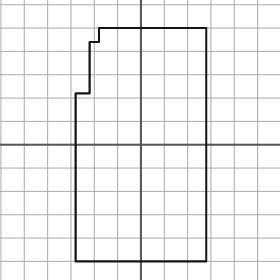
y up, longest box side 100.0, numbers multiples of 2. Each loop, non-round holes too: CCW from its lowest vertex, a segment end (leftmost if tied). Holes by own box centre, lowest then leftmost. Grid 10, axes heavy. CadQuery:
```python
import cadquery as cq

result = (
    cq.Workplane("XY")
    .moveTo(-28.0, -50.0)
    .lineTo(28.0, -50.0)
    .lineTo(28.0, 50.0)
    .lineTo(-18.0, 50.0)
    .lineTo(-18.0, 44.0)
    .lineTo(-22.0, 44.0)
    .lineTo(-22.0, 22.0)
    .lineTo(-28.0, 22.0)
    .close()
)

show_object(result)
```